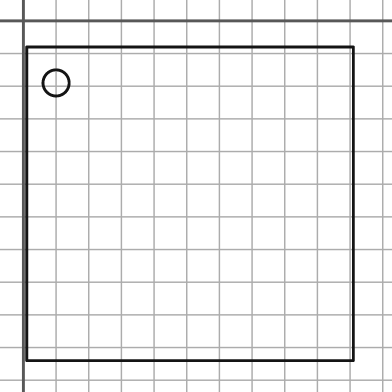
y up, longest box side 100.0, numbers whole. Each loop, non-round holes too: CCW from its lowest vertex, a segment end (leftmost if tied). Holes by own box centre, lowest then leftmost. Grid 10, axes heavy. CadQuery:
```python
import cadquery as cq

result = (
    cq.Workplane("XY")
    .moveTo(1.0, -104.0)
    .lineTo(101.0, -104.0)
    .lineTo(101.0, -8.0)
    .lineTo(1.0, -8.0)
    .close()
    .moveTo(10.0, -19.0)
    .circle(4.0)
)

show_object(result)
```